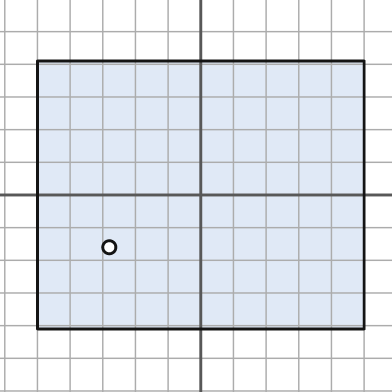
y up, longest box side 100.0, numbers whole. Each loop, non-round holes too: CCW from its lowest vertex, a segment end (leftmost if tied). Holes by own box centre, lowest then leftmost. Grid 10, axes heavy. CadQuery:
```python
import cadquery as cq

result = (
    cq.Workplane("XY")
    .moveTo(-50.0, -41.0)
    .lineTo(50.0, -41.0)
    .lineTo(50.0, 41.0)
    .lineTo(-50.0, 41.0)
    .close()
    .moveTo(-28.0, -16.0)
    .circle(2.0)
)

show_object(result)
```